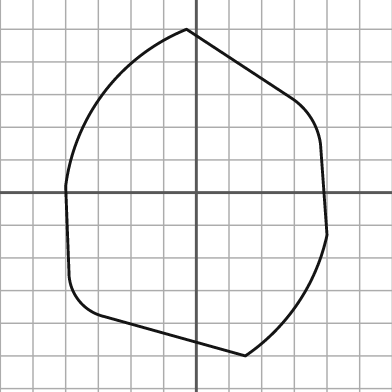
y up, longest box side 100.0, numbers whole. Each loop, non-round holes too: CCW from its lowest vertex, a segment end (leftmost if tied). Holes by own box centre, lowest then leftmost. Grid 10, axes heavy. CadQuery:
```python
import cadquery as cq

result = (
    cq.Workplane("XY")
    .moveTo(15.0, -50.0)
    .threePointArc((31.0, -34.0), (40.0, -13.0))
    .lineTo(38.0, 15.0)
    .threePointArc((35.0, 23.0), (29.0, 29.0))
    .lineTo(-3.0, 50.0)
    .threePointArc((-28.0, 31.0), (-40.0, 2.0))
    .lineTo(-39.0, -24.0)
    .threePointArc((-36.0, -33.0), (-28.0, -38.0))
    .close()
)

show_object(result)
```